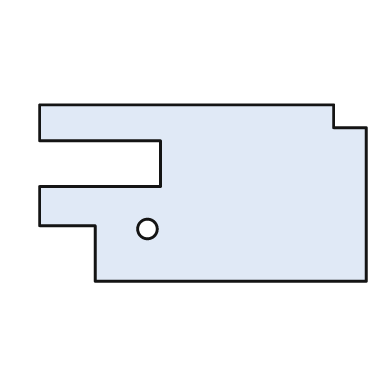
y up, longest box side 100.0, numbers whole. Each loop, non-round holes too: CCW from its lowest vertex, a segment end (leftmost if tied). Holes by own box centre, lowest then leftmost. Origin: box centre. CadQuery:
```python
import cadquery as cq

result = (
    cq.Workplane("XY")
    .moveTo(-33.0, -27.0)
    .lineTo(50.0, -27.0)
    .lineTo(50.0, 20.0)
    .lineTo(40.0, 20.0)
    .lineTo(40.0, 27.0)
    .lineTo(-50.0, 27.0)
    .lineTo(-50.0, 16.0)
    .lineTo(-13.0, 16.0)
    .lineTo(-13.0, 2.0)
    .lineTo(-50.0, 2.0)
    .lineTo(-50.0, -10.0)
    .lineTo(-33.0, -10.0)
    .close()
    .moveTo(-17.0, -11.0)
    .circle(3.0)
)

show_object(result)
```